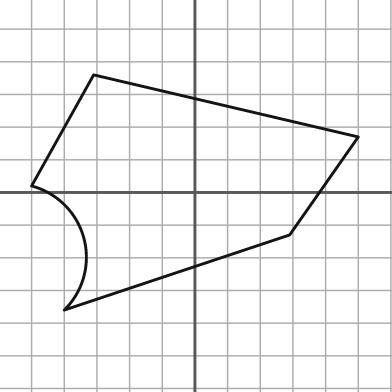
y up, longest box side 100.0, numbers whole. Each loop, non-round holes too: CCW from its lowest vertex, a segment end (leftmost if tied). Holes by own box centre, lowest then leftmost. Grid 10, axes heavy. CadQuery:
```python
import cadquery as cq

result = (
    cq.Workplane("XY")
    .moveTo(-40.0, -36.0)
    .lineTo(29.0, -13.0)
    .lineTo(50.0, 17.0)
    .lineTo(-31.0, 36.0)
    .lineTo(-50.0, 2.0)
    .threePointArc((-34.0, -14.0), (-40.0, -36.0))
    .close()
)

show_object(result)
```